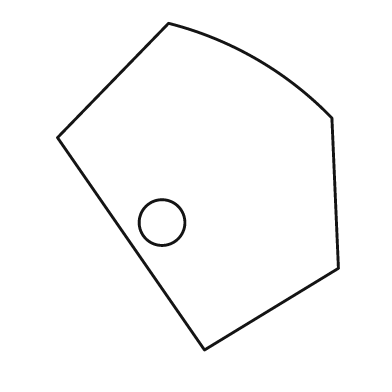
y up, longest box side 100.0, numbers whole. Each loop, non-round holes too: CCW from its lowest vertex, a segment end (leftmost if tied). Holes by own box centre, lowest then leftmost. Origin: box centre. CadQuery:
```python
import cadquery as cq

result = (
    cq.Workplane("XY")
    .moveTo(2.0, -50.0)
    .lineTo(43.0, -25.0)
    .lineTo(41.0, 21.0)
    .threePointArc((18.0, 39.0), (-9.0, 50.0))
    .lineTo(-43.0, 15.0)
    .close()
    .moveTo(-11.0, -11.0)
    .circle(7.0)
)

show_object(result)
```